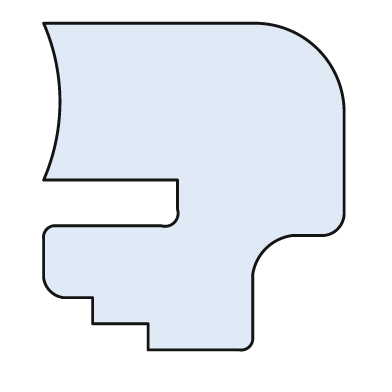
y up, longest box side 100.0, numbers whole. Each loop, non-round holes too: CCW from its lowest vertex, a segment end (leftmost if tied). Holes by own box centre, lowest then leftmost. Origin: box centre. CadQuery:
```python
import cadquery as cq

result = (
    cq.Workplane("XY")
    .moveTo(-14.0, -50.0)
    .lineTo(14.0, -50.0)
    .threePointArc((17.0, -49.0), (18.0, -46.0))
    .lineTo(18.0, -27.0)
    .threePointArc((22.0, -19.0), (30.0, -15.0))
    .lineTo(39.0, -15.0)
    .threePointArc((44.0, -13.0), (46.0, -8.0))
    .lineTo(46.0, 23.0)
    .threePointArc((38.0, 42.0), (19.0, 50.0))
    .lineTo(-46.0, 50.0)
    .threePointArc((-41.0, 26.0), (-46.0, 2.0))
    .lineTo(-5.0, 2.0)
    .lineTo(-5.0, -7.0)
    .threePointArc((-6.0, -11.0), (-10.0, -12.0))
    .lineTo(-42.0, -12.0)
    .threePointArc((-45.0, -13.0), (-46.0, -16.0))
    .lineTo(-46.0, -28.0)
    .threePointArc((-44.0, -32.0), (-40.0, -34.0))
    .lineTo(-31.0, -34.0)
    .lineTo(-31.0, -42.0)
    .lineTo(-14.0, -42.0)
    .close()
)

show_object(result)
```